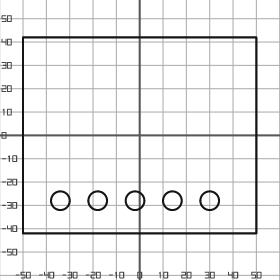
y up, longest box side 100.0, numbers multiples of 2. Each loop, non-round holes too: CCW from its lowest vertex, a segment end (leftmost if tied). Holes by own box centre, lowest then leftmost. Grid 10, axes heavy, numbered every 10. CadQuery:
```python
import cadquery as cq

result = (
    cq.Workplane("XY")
    .moveTo(-50.0, -42.0)
    .lineTo(50.0, -42.0)
    .lineTo(50.0, 42.0)
    .lineTo(-50.0, 42.0)
    .close()
    .moveTo(-34.0, -28.0)
    .circle(4.0)
    .moveTo(-18.0, -28.0)
    .circle(4.0)
    .moveTo(-2.0, -28.0)
    .circle(4.0)
    .moveTo(14.0, -28.0)
    .circle(4.0)
    .moveTo(30.0, -28.0)
    .circle(4.0)
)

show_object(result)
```